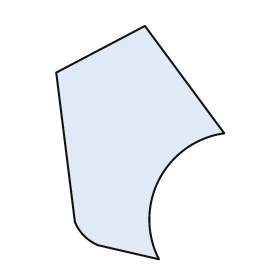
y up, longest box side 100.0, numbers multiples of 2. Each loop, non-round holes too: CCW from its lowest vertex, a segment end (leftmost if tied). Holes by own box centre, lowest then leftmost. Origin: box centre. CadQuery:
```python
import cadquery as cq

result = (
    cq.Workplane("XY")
    .moveTo(8.0, -50.0)
    .threePointArc((8.0, -16.0), (36.0, 4.0))
    .lineTo(2.0, 50.0)
    .lineTo(-36.0, 30.0)
    .lineTo(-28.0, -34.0)
    .threePointArc((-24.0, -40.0), (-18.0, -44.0))
    .close()
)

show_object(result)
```